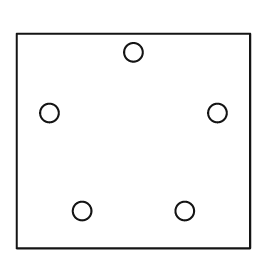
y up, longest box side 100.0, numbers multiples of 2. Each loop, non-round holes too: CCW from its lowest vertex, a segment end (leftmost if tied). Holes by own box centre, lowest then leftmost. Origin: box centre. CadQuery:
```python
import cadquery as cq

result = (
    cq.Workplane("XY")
    .moveTo(-50.0, -46.0)
    .lineTo(50.0, -46.0)
    .lineTo(50.0, 46.0)
    .lineTo(-50.0, 46.0)
    .close()
    .moveTo(-22.0, -30.0)
    .circle(4.0)
    .moveTo(22.0, -30.0)
    .circle(4.0)
    .moveTo(-36.0, 12.0)
    .circle(4.0)
    .moveTo(36.0, 12.0)
    .circle(4.0)
    .moveTo(0.0, 38.0)
    .circle(4.0)
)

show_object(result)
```